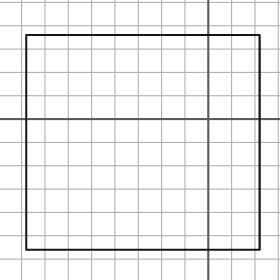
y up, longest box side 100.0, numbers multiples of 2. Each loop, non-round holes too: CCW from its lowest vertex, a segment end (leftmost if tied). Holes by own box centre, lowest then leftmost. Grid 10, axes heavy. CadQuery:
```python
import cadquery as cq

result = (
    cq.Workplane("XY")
    .moveTo(-78.0, -56.0)
    .lineTo(22.0, -56.0)
    .lineTo(22.0, 36.0)
    .lineTo(-78.0, 36.0)
    .close()
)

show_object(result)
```